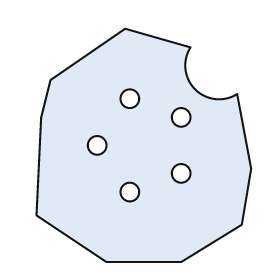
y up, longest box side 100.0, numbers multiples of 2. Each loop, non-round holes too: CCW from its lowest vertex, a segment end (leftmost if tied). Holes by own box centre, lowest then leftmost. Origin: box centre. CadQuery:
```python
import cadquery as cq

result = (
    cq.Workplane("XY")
    .moveTo(-16.0, -50.0)
    .lineTo(16.0, -50.0)
    .lineTo(42.0, -34.0)
    .lineTo(46.0, -10.0)
    .lineTo(40.0, 22.0)
    .threePointArc((22.0, 24.0), (20.0, 42.0))
    .lineTo(-8.0, 50.0)
    .lineTo(-40.0, 28.0)
    .lineTo(-44.0, 12.0)
    .lineTo(-46.0, -30.0)
    .close()
    .moveTo(-6.0, -20.0)
    .circle(4.0)
    .moveTo(16.0, -12.0)
    .circle(4.0)
    .moveTo(-20.0, 0.0)
    .circle(4.0)
    .moveTo(16.0, 12.0)
    .circle(4.0)
    .moveTo(-6.0, 20.0)
    .circle(4.0)
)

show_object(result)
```